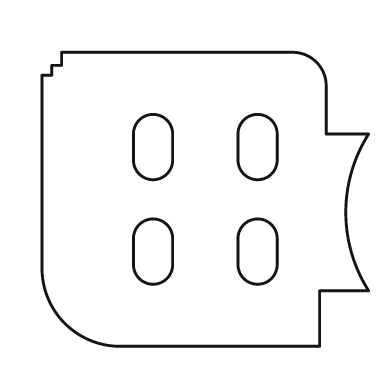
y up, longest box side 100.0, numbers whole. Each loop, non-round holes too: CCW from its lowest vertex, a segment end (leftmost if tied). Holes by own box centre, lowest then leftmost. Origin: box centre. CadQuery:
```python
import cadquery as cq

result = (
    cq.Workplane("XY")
    .moveTo(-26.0, -45.0)
    .lineTo(35.0, -45.0)
    .lineTo(35.0, -28.0)
    .lineTo(50.0, -28.0)
    .threePointArc((43.0, -4.0), (50.0, 20.0))
    .lineTo(37.0, 20.0)
    .lineTo(37.0, 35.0)
    .threePointArc((34.0, 42.0), (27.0, 45.0))
    .lineTo(-44.0, 45.0)
    .lineTo(-44.0, 41.0)
    .lineTo(-47.0, 41.0)
    .lineTo(-47.0, 38.0)
    .lineTo(-50.0, 38.0)
    .lineTo(-50.0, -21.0)
    .threePointArc((-43.0, -38.0), (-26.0, -45.0))
    .close()
    .moveTo(-22.0, -20.0)
    .threePointArc((-16.0, -26.0), (-10.0, -20.0))
    .lineTo(-10.0, -12.0)
    .threePointArc((-16.0, -6.0), (-22.0, -12.0))
    .close()
    .moveTo(10.0, -20.0)
    .threePointArc((16.0, -26.0), (22.0, -20.0))
    .lineTo(22.0, -12.0)
    .threePointArc((16.0, -6.0), (10.0, -12.0))
    .close()
    .moveTo(-22.0, 12.0)
    .threePointArc((-16.0, 6.0), (-10.0, 12.0))
    .lineTo(-10.0, 20.0)
    .threePointArc((-16.0, 26.0), (-22.0, 20.0))
    .close()
    .moveTo(10.0, 12.0)
    .threePointArc((16.0, 6.0), (22.0, 12.0))
    .lineTo(22.0, 20.0)
    .threePointArc((16.0, 26.0), (10.0, 20.0))
    .close()
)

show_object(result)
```